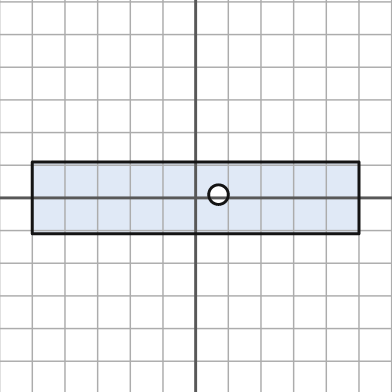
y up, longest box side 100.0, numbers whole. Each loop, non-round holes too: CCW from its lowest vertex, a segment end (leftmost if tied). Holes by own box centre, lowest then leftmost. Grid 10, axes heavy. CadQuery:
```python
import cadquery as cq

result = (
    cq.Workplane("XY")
    .moveTo(-50.0, -11.0)
    .lineTo(50.0, -11.0)
    .lineTo(50.0, 11.0)
    .lineTo(-50.0, 11.0)
    .close()
    .moveTo(7.0, 1.0)
    .circle(3.0)
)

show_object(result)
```